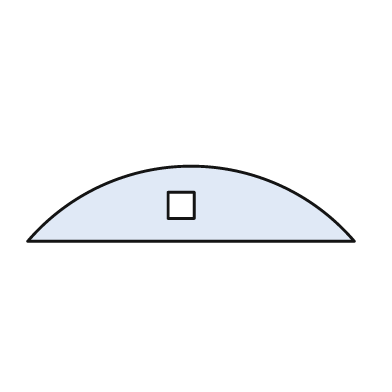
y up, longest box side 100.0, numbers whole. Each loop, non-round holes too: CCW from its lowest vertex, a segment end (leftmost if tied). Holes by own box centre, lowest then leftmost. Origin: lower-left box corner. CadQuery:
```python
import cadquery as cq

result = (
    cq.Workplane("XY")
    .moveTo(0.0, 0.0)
    .lineTo(100.0, 0.0)
    .threePointArc((50.0, 23.0), (0.0, 0.0))
    .close()
    .moveTo(43.0, 7.0)
    .lineTo(51.0, 7.0)
    .lineTo(51.0, 15.0)
    .lineTo(43.0, 15.0)
    .close()
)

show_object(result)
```